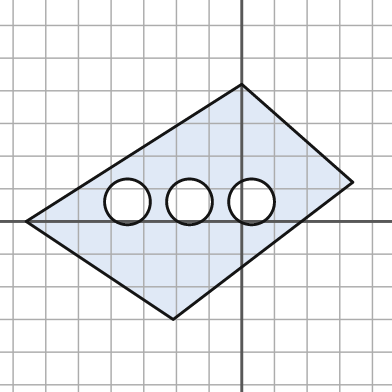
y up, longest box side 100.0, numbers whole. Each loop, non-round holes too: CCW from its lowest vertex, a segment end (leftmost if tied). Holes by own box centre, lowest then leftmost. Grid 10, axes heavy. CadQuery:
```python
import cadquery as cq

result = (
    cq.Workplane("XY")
    .moveTo(-21.0, -30.0)
    .lineTo(34.0, 12.0)
    .lineTo(0.0, 42.0)
    .lineTo(-66.0, 0.0)
    .close()
    .moveTo(-35.0, 6.0)
    .circle(7.0)
    .moveTo(-16.0, 6.0)
    .circle(7.0)
    .moveTo(3.0, 6.0)
    .circle(7.0)
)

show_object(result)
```